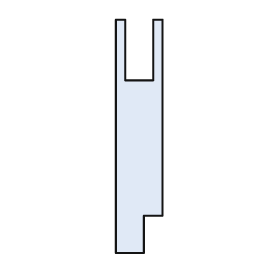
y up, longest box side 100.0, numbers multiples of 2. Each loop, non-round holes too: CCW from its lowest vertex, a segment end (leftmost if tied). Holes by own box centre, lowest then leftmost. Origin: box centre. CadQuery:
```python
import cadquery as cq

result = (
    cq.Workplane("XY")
    .moveTo(-10.0, -50.0)
    .lineTo(2.0, -50.0)
    .lineTo(2.0, -34.0)
    .lineTo(10.0, -34.0)
    .lineTo(10.0, 50.0)
    .lineTo(6.0, 50.0)
    .lineTo(6.0, 24.0)
    .lineTo(-6.0, 24.0)
    .lineTo(-6.0, 50.0)
    .lineTo(-10.0, 50.0)
    .close()
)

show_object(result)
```